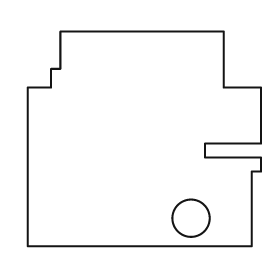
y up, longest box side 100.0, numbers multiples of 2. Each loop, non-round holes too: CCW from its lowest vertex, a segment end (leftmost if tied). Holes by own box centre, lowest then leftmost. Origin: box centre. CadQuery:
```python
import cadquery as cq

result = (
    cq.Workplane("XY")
    .moveTo(-50.0, -46.0)
    .lineTo(46.0, -46.0)
    .lineTo(46.0, -14.0)
    .lineTo(50.0, -14.0)
    .lineTo(50.0, -8.0)
    .lineTo(26.0, -8.0)
    .lineTo(26.0, -2.0)
    .lineTo(50.0, -2.0)
    .lineTo(50.0, 22.0)
    .lineTo(34.0, 22.0)
    .lineTo(34.0, 46.0)
    .lineTo(-36.0, 46.0)
    .lineTo(-36.0, 30.0)
    .lineTo(-40.0, 30.0)
    .lineTo(-40.0, 22.0)
    .lineTo(-50.0, 22.0)
    .close()
    .moveTo(20.0, -34.0)
    .circle(8.0)
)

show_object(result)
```